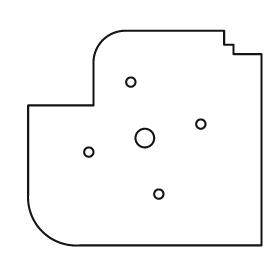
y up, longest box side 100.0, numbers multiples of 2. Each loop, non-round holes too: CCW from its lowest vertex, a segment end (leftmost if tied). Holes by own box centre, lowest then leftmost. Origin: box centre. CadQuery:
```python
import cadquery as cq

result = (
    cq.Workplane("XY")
    .moveTo(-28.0, -46.0)
    .lineTo(50.0, -46.0)
    .lineTo(50.0, 36.0)
    .lineTo(38.0, 36.0)
    .lineTo(38.0, 40.0)
    .lineTo(34.0, 40.0)
    .lineTo(34.0, 46.0)
    .lineTo(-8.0, 46.0)
    .threePointArc((-18.0, 42.0), (-22.0, 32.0))
    .lineTo(-22.0, 14.0)
    .lineTo(-50.0, 14.0)
    .lineTo(-50.0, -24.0)
    .threePointArc((-44.0, -40.0), (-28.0, -46.0))
    .close()
    .moveTo(6.0, -24.0)
    .circle(2.0)
    .moveTo(-24.0, -6.0)
    .circle(2.0)
    .moveTo(0.0, 0.0)
    .circle(4.0)
    .moveTo(24.0, 6.0)
    .circle(2.0)
    .moveTo(-6.0, 24.0)
    .circle(2.0)
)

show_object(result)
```